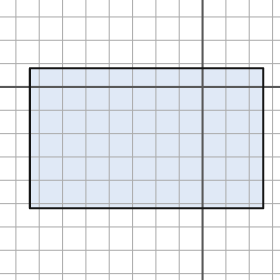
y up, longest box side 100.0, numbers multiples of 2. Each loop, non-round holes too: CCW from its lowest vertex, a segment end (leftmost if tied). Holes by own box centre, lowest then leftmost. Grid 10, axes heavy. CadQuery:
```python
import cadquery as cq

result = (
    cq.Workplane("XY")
    .moveTo(-74.0, -52.0)
    .lineTo(26.0, -52.0)
    .lineTo(26.0, 8.0)
    .lineTo(-74.0, 8.0)
    .close()
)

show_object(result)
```